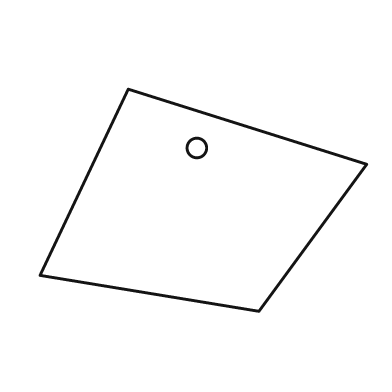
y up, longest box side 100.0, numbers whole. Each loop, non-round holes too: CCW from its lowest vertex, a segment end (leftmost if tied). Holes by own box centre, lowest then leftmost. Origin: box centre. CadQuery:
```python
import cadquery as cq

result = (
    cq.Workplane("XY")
    .moveTo(17.0, -34.0)
    .lineTo(50.0, 11.0)
    .lineTo(-23.0, 34.0)
    .lineTo(-50.0, -23.0)
    .close()
    .moveTo(-2.0, 16.0)
    .circle(3.0)
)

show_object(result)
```